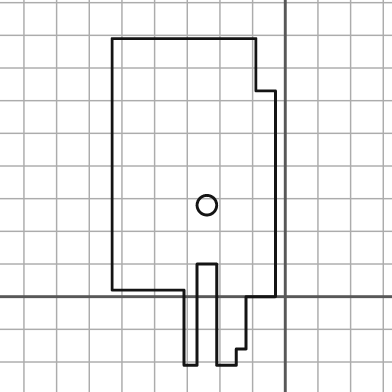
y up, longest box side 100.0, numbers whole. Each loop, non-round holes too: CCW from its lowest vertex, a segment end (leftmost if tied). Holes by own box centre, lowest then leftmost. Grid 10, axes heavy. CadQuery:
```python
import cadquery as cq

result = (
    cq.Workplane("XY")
    .moveTo(-31.0, -21.0)
    .lineTo(-27.0, -21.0)
    .lineTo(-27.0, 10.0)
    .lineTo(-21.0, 10.0)
    .lineTo(-21.0, -21.0)
    .lineTo(-15.0, -21.0)
    .lineTo(-15.0, -16.0)
    .lineTo(-12.0, -16.0)
    .lineTo(-12.0, 0.0)
    .lineTo(-3.0, 0.0)
    .lineTo(-3.0, 63.0)
    .lineTo(-9.0, 63.0)
    .lineTo(-9.0, 79.0)
    .lineTo(-53.0, 79.0)
    .lineTo(-53.0, 2.0)
    .lineTo(-31.0, 2.0)
    .close()
    .moveTo(-24.0, 28.0)
    .circle(3.0)
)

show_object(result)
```